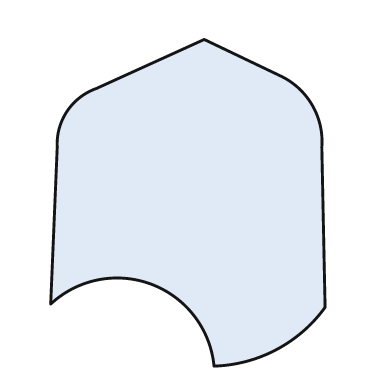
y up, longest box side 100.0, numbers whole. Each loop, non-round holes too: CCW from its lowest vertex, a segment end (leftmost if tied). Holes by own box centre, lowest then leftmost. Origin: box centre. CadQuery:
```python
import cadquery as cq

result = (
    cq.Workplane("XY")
    .moveTo(8.0, -50.0)
    .threePointArc((27.0, -45.0), (42.0, -32.0))
    .lineTo(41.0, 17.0)
    .threePointArc((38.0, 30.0), (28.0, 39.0))
    .lineTo(5.0, 50.0)
    .lineTo(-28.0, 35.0)
    .threePointArc((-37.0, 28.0), (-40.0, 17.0))
    .lineTo(-42.0, -31.0)
    .threePointArc((-11.0, -25.0), (8.0, -50.0))
    .close()
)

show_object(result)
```